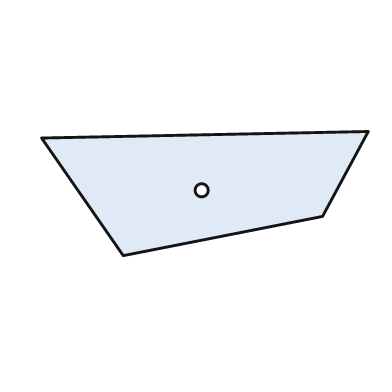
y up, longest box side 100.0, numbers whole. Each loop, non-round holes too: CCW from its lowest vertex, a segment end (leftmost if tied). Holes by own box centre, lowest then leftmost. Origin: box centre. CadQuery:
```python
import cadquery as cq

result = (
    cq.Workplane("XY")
    .moveTo(-25.0, -19.0)
    .lineTo(36.0, -7.0)
    .lineTo(50.0, 19.0)
    .lineTo(-50.0, 17.0)
    .close()
    .moveTo(-1.0, 1.0)
    .circle(2.0)
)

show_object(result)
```